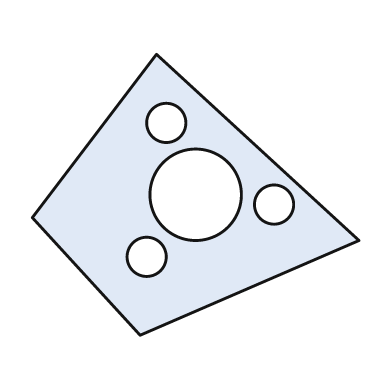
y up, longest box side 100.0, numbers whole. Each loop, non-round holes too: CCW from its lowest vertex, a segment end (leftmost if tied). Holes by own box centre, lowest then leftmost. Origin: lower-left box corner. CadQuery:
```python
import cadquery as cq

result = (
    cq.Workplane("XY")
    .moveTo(33.0, 0.0)
    .lineTo(100.0, 29.0)
    .lineTo(38.0, 86.0)
    .lineTo(0.0, 36.0)
    .close()
    .moveTo(35.0, 24.0)
    .circle(6.0)
    .moveTo(74.0, 40.0)
    .circle(6.0)
    .moveTo(50.0, 43.0)
    .circle(14.0)
    .moveTo(41.0, 65.0)
    .circle(6.0)
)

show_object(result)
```